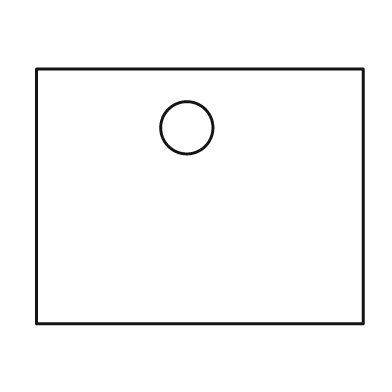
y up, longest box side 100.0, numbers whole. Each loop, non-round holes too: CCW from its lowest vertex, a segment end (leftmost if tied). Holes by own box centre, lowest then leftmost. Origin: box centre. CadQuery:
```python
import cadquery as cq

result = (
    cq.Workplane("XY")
    .moveTo(-50.0, -39.0)
    .lineTo(50.0, -39.0)
    .lineTo(50.0, 39.0)
    .lineTo(-50.0, 39.0)
    .close()
    .moveTo(-4.0, 21.0)
    .circle(8.0)
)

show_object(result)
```